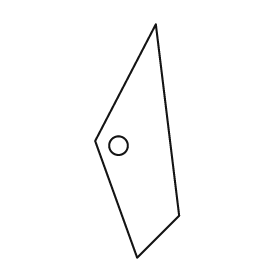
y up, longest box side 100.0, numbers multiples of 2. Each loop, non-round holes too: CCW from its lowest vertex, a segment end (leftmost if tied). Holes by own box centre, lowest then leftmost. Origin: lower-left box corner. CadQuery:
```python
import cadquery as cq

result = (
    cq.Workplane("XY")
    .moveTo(18.0, 0.0)
    .lineTo(36.0, 18.0)
    .lineTo(26.0, 100.0)
    .lineTo(0.0, 50.0)
    .close()
    .moveTo(10.0, 48.0)
    .circle(4.0)
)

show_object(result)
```